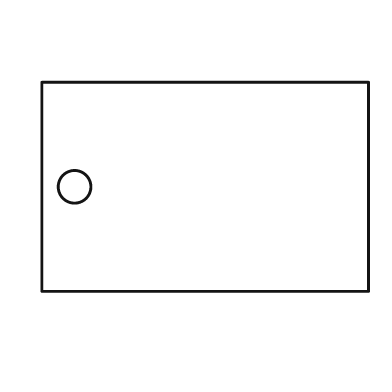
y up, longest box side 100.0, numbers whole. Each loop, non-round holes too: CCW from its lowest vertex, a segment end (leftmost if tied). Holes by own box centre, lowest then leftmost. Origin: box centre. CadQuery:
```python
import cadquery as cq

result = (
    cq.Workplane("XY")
    .moveTo(-50.0, -32.0)
    .lineTo(50.0, -32.0)
    .lineTo(50.0, 32.0)
    .lineTo(-50.0, 32.0)
    .close()
    .moveTo(-40.0, 0.0)
    .circle(5.0)
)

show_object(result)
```